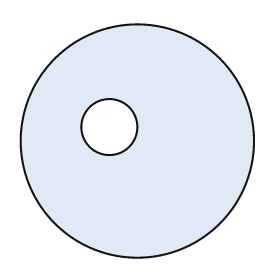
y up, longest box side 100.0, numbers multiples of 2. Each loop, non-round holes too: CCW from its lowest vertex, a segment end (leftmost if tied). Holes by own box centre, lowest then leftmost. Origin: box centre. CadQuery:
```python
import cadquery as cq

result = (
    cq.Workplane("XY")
    .moveTo(0.0, 0.0)
    .circle(50.0)
    .moveTo(-12.0, 6.0)
    .circle(12.0)
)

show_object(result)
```